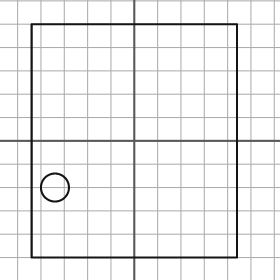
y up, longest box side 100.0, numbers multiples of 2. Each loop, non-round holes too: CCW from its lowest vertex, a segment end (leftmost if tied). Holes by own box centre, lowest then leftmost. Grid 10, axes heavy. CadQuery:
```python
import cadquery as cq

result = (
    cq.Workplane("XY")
    .moveTo(-44.0, -50.0)
    .lineTo(44.0, -50.0)
    .lineTo(44.0, 50.0)
    .lineTo(-44.0, 50.0)
    .close()
    .moveTo(-34.0, -20.0)
    .circle(6.0)
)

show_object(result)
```